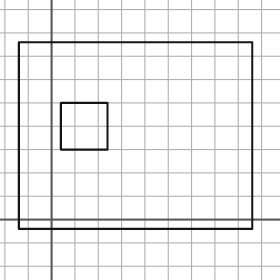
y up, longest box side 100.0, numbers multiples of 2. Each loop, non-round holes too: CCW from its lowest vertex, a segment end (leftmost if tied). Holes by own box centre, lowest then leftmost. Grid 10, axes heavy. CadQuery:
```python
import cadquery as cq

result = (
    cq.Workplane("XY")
    .moveTo(-14.0, -4.0)
    .lineTo(86.0, -4.0)
    .lineTo(86.0, 76.0)
    .lineTo(-14.0, 76.0)
    .close()
    .moveTo(4.0, 30.0)
    .lineTo(24.0, 30.0)
    .lineTo(24.0, 50.0)
    .lineTo(4.0, 50.0)
    .close()
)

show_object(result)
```